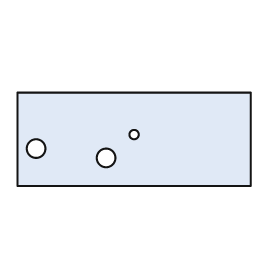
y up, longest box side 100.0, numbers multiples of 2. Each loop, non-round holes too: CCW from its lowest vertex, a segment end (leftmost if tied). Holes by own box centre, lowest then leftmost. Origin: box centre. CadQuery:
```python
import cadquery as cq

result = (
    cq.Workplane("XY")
    .moveTo(-50.0, -20.0)
    .lineTo(50.0, -20.0)
    .lineTo(50.0, 20.0)
    .lineTo(-50.0, 20.0)
    .close()
    .moveTo(-12.0, -8.0)
    .circle(4.0)
    .moveTo(-42.0, -4.0)
    .circle(4.0)
    .moveTo(0.0, 2.0)
    .circle(2.0)
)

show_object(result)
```